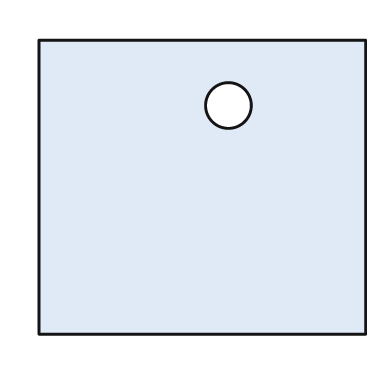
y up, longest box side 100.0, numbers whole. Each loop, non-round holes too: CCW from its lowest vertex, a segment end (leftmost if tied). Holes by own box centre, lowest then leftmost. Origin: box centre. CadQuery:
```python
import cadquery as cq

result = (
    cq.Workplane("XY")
    .moveTo(-50.0, -45.0)
    .lineTo(50.0, -45.0)
    .lineTo(50.0, 45.0)
    .lineTo(-50.0, 45.0)
    .close()
    .moveTo(8.0, 25.0)
    .circle(7.0)
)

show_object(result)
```